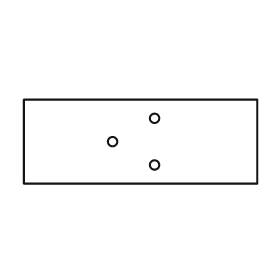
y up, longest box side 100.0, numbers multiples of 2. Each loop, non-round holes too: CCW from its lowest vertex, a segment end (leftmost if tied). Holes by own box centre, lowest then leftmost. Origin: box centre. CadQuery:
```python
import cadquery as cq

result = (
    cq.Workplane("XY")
    .moveTo(-50.0, -18.0)
    .lineTo(50.0, -18.0)
    .lineTo(50.0, 18.0)
    .lineTo(-50.0, 18.0)
    .close()
    .moveTo(6.0, -10.0)
    .circle(2.0)
    .moveTo(-12.0, 0.0)
    .circle(2.0)
    .moveTo(6.0, 10.0)
    .circle(2.0)
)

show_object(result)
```